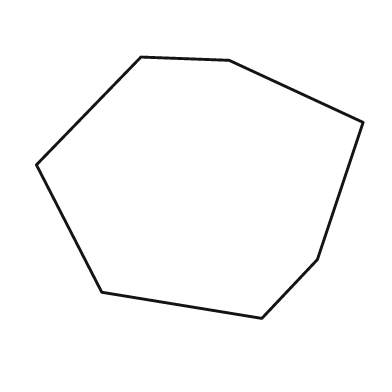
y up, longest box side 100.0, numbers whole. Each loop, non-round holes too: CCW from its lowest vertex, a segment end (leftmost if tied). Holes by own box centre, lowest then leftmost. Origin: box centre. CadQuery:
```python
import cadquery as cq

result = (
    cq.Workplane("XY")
    .moveTo(19.0, -40.0)
    .lineTo(36.0, -22.0)
    .lineTo(50.0, 20.0)
    .lineTo(9.0, 39.0)
    .lineTo(-18.0, 40.0)
    .lineTo(-50.0, 7.0)
    .lineTo(-30.0, -32.0)
    .close()
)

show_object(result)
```